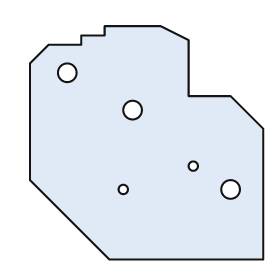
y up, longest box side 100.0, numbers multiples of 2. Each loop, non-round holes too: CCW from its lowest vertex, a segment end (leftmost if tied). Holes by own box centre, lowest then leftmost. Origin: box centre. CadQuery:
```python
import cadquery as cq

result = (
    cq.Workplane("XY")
    .moveTo(-16.0, -50.0)
    .lineTo(50.0, -50.0)
    .lineTo(50.0, 6.0)
    .lineTo(36.0, 20.0)
    .lineTo(18.0, 20.0)
    .lineTo(18.0, 44.0)
    .lineTo(6.0, 50.0)
    .lineTo(-18.0, 50.0)
    .lineTo(-18.0, 46.0)
    .lineTo(-28.0, 46.0)
    .lineTo(-28.0, 42.0)
    .lineTo(-42.0, 42.0)
    .lineTo(-50.0, 34.0)
    .lineTo(-50.0, -16.0)
    .close()
    .moveTo(-10.0, -20.0)
    .circle(2.0)
    .moveTo(36.0, -20.0)
    .circle(4.0)
    .moveTo(20.0, -10.0)
    .circle(2.0)
    .moveTo(-6.0, 14.0)
    .circle(4.0)
    .moveTo(-34.0, 30.0)
    .circle(4.0)
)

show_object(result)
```